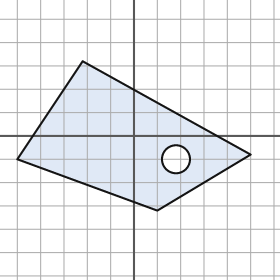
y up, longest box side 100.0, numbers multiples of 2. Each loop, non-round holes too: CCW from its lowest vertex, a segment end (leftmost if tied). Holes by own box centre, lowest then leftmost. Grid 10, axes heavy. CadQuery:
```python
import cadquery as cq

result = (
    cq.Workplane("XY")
    .moveTo(10.0, -32.0)
    .lineTo(50.0, -8.0)
    .lineTo(-22.0, 32.0)
    .lineTo(-50.0, -10.0)
    .close()
    .moveTo(18.0, -10.0)
    .circle(6.0)
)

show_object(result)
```